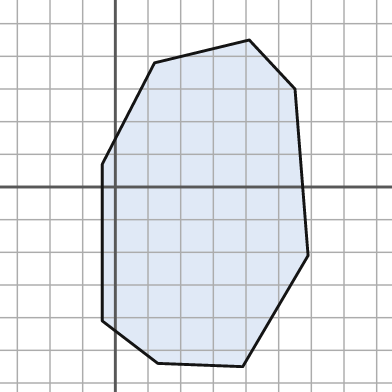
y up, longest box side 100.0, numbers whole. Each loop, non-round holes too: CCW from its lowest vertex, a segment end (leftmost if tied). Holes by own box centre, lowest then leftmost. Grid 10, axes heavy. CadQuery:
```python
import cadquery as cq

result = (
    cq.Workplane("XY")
    .moveTo(39.0, -55.0)
    .lineTo(59.0, -21.0)
    .lineTo(55.0, 30.0)
    .lineTo(41.0, 45.0)
    .lineTo(12.0, 38.0)
    .lineTo(-4.0, 7.0)
    .lineTo(-4.0, -41.0)
    .lineTo(13.0, -54.0)
    .close()
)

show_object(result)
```